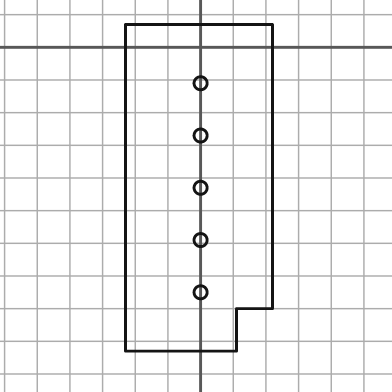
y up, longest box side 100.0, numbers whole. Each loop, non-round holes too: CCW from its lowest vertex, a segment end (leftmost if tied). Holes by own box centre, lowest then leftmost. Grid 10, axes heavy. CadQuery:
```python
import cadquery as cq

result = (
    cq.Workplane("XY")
    .moveTo(-23.0, -93.0)
    .lineTo(11.0, -93.0)
    .lineTo(11.0, -80.0)
    .lineTo(22.0, -80.0)
    .lineTo(22.0, 7.0)
    .lineTo(-23.0, 7.0)
    .close()
    .moveTo(0.0, -75.0)
    .circle(2.0)
    .moveTo(0.0, -59.0)
    .circle(2.0)
    .moveTo(0.0, -43.0)
    .circle(2.0)
    .moveTo(0.0, -27.0)
    .circle(2.0)
    .moveTo(0.0, -11.0)
    .circle(2.0)
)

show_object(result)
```